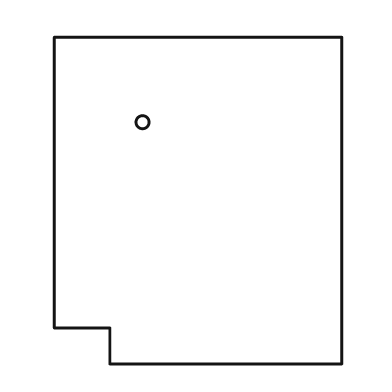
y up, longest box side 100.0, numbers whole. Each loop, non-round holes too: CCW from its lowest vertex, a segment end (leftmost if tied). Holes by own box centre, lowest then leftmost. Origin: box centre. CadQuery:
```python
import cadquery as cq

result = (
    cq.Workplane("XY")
    .moveTo(-27.0, -50.0)
    .lineTo(44.0, -50.0)
    .lineTo(44.0, 50.0)
    .lineTo(-44.0, 50.0)
    .lineTo(-44.0, -39.0)
    .lineTo(-27.0, -39.0)
    .close()
    .moveTo(-17.0, 24.0)
    .circle(2.0)
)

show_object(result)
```